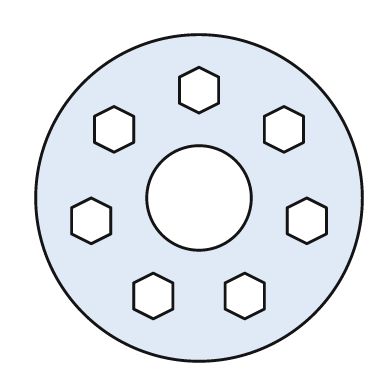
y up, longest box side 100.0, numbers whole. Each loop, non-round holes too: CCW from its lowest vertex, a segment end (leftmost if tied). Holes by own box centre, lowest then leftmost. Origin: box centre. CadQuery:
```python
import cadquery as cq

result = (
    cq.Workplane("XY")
    .moveTo(0.0, 0.0)
    .circle(50.0)
    .moveTo(-14.0, -37.0)
    .lineTo(-8.0, -34.0)
    .lineTo(-8.0, -26.0)
    .lineTo(-14.0, -23.0)
    .lineTo(-20.0, -26.0)
    .lineTo(-20.0, -34.0)
    .close()
    .moveTo(14.0, -37.0)
    .lineTo(20.0, -34.0)
    .lineTo(20.0, -26.0)
    .lineTo(14.0, -23.0)
    .lineTo(8.0, -26.0)
    .lineTo(8.0, -34.0)
    .close()
    .moveTo(-33.0, -14.0)
    .lineTo(-27.0, -11.0)
    .lineTo(-27.0, -3.0)
    .lineTo(-33.0, 0.0)
    .lineTo(-39.0, -3.0)
    .lineTo(-39.0, -11.0)
    .close()
    .moveTo(33.0, -14.0)
    .lineTo(39.0, -11.0)
    .lineTo(39.0, -3.0)
    .lineTo(33.0, 0.0)
    .lineTo(27.0, -3.0)
    .lineTo(27.0, -11.0)
    .close()
    .moveTo(0.0, 0.0)
    .circle(16.0)
    .moveTo(-26.0, 14.0)
    .lineTo(-20.0, 17.0)
    .lineTo(-20.0, 25.0)
    .lineTo(-26.0, 28.0)
    .lineTo(-32.0, 25.0)
    .lineTo(-32.0, 17.0)
    .close()
    .moveTo(26.0, 14.0)
    .lineTo(32.0, 17.0)
    .lineTo(32.0, 25.0)
    .lineTo(26.0, 28.0)
    .lineTo(20.0, 25.0)
    .lineTo(20.0, 17.0)
    .close()
    .moveTo(0.0, 26.0)
    .lineTo(6.0, 29.0)
    .lineTo(6.0, 37.0)
    .lineTo(0.0, 40.0)
    .lineTo(-6.0, 37.0)
    .lineTo(-6.0, 29.0)
    .close()
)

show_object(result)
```